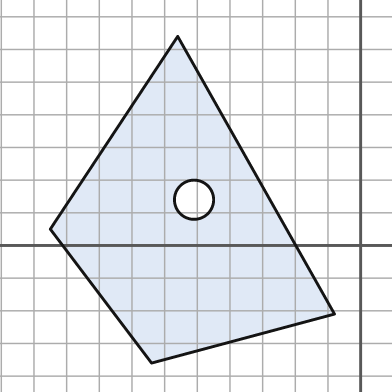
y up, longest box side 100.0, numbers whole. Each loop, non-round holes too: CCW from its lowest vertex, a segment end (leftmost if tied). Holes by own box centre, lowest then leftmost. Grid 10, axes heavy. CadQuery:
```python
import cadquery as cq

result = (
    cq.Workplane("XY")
    .moveTo(-64.0, -36.0)
    .lineTo(-8.0, -21.0)
    .lineTo(-56.0, 64.0)
    .lineTo(-95.0, 5.0)
    .close()
    .moveTo(-51.0, 14.0)
    .circle(6.0)
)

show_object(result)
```